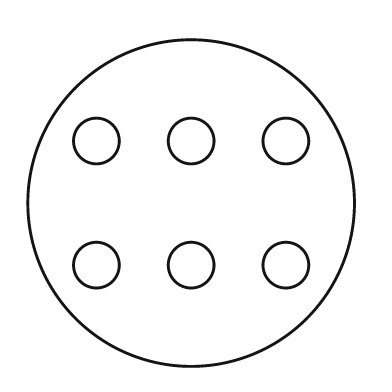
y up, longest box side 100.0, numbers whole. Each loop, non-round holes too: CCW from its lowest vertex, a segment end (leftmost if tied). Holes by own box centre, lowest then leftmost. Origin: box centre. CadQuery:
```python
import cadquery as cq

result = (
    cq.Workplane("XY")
    .moveTo(0.0, 0.0)
    .circle(50.0)
    .moveTo(-29.0, -19.0)
    .circle(7.0)
    .moveTo(0.0, -19.0)
    .circle(7.0)
    .moveTo(29.0, -19.0)
    .circle(7.0)
    .moveTo(-29.0, 19.0)
    .circle(7.0)
    .moveTo(0.0, 19.0)
    .circle(7.0)
    .moveTo(29.0, 19.0)
    .circle(7.0)
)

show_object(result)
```